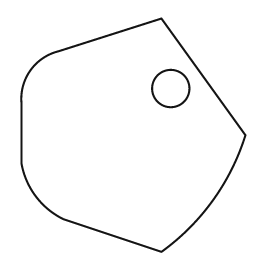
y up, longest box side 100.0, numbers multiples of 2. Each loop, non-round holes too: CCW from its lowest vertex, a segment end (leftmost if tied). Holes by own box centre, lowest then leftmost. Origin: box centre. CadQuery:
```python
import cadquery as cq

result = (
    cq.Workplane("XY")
    .moveTo(12.0, -50.0)
    .threePointArc((34.0, -28.0), (48.0, 0.0))
    .lineTo(12.0, 50.0)
    .lineTo(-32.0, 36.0)
    .threePointArc((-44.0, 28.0), (-48.0, 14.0))
    .lineTo(-48.0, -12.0)
    .threePointArc((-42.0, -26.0), (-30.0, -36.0))
    .close()
    .moveTo(16.0, 20.0)
    .circle(8.0)
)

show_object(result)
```